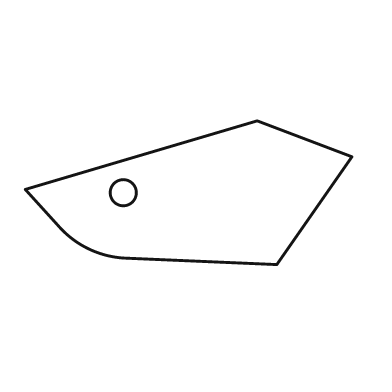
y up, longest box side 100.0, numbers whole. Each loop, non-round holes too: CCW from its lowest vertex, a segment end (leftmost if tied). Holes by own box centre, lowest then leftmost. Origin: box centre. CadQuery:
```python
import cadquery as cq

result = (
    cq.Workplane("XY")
    .moveTo(27.0, -22.0)
    .lineTo(50.0, 11.0)
    .lineTo(21.0, 22.0)
    .lineTo(-50.0, 1.0)
    .lineTo(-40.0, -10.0)
    .threePointArc((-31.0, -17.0), (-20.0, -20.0))
    .close()
    .moveTo(-20.0, 0.0)
    .circle(4.0)
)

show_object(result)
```